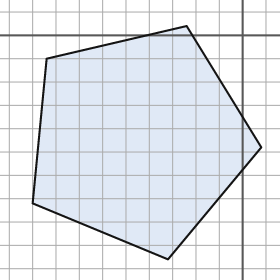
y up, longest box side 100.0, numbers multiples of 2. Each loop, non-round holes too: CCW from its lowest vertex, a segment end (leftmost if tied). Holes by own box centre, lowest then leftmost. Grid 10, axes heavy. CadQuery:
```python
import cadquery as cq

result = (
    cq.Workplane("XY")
    .moveTo(-32.0, -96.0)
    .lineTo(8.0, -48.0)
    .lineTo(-24.0, 4.0)
    .lineTo(-84.0, -10.0)
    .lineTo(-90.0, -72.0)
    .close()
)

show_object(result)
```